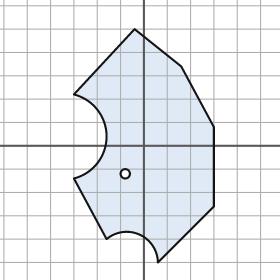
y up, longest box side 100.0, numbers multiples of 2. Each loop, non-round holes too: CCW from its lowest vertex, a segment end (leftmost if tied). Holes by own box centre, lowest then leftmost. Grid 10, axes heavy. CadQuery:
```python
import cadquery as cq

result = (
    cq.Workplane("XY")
    .moveTo(6.0, -50.0)
    .lineTo(30.0, -26.0)
    .lineTo(30.0, 8.0)
    .lineTo(16.0, 34.0)
    .lineTo(-4.0, 50.0)
    .lineTo(-30.0, 22.0)
    .threePointArc((-16.0, 4.0), (-30.0, -14.0))
    .lineTo(-16.0, -40.0)
    .threePointArc((-2.0, -38.0), (6.0, -50.0))
    .close()
    .moveTo(-8.0, -12.0)
    .circle(2.0)
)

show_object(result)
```